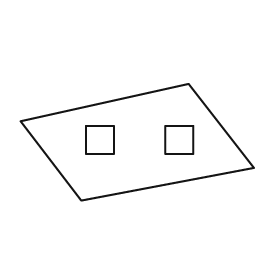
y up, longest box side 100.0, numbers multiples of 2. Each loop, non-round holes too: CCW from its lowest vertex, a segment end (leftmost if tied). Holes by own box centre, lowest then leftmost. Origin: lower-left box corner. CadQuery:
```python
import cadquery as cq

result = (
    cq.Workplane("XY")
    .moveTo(26.0, 0.0)
    .lineTo(100.0, 14.0)
    .lineTo(72.0, 50.0)
    .lineTo(0.0, 34.0)
    .close()
    .moveTo(28.0, 20.0)
    .lineTo(40.0, 20.0)
    .lineTo(40.0, 32.0)
    .lineTo(28.0, 32.0)
    .close()
    .moveTo(62.0, 20.0)
    .lineTo(74.0, 20.0)
    .lineTo(74.0, 32.0)
    .lineTo(62.0, 32.0)
    .close()
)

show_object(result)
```